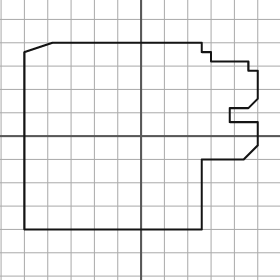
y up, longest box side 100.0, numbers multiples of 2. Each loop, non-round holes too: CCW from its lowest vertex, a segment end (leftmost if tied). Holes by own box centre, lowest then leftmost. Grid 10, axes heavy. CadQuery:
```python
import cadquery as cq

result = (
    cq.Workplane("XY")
    .moveTo(-50.0, -40.0)
    .lineTo(26.0, -40.0)
    .lineTo(26.0, -10.0)
    .lineTo(44.0, -10.0)
    .lineTo(50.0, -4.0)
    .lineTo(50.0, 6.0)
    .lineTo(38.0, 6.0)
    .lineTo(38.0, 12.0)
    .lineTo(46.0, 12.0)
    .lineTo(50.0, 16.0)
    .lineTo(50.0, 28.0)
    .lineTo(46.0, 28.0)
    .lineTo(46.0, 32.0)
    .lineTo(30.0, 32.0)
    .lineTo(30.0, 36.0)
    .lineTo(26.0, 36.0)
    .lineTo(26.0, 40.0)
    .lineTo(-38.0, 40.0)
    .lineTo(-50.0, 36.0)
    .close()
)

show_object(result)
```